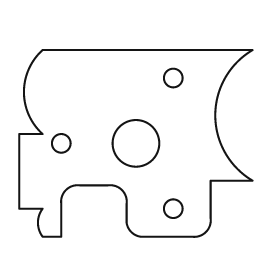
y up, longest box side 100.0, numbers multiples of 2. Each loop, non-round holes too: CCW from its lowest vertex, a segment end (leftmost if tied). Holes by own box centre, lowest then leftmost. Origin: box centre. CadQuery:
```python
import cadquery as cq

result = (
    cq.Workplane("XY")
    .moveTo(-40.0, -40.0)
    .lineTo(-32.0, -40.0)
    .lineTo(-32.0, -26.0)
    .threePointArc((-30.0, -20.0), (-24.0, -18.0))
    .lineTo(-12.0, -18.0)
    .threePointArc((-6.0, -20.0), (-4.0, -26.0))
    .lineTo(-4.0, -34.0)
    .threePointArc((-2.0, -38.0), (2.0, -40.0))
    .lineTo(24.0, -40.0)
    .threePointArc((30.0, -38.0), (32.0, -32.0))
    .lineTo(32.0, -16.0)
    .lineTo(50.0, -16.0)
    .threePointArc((34.0, 12.0), (50.0, 40.0))
    .lineTo(-40.0, 40.0)
    .threePointArc((-48.0, 22.0), (-40.0, 4.0))
    .lineTo(-50.0, 4.0)
    .lineTo(-50.0, -28.0)
    .lineTo(-40.0, -28.0)
    .threePointArc((-42.0, -34.0), (-40.0, -40.0))
    .close()
    .moveTo(16.0, -28.0)
    .circle(4.0)
    .moveTo(-32.0, 0.0)
    .circle(4.0)
    .moveTo(0.0, 0.0)
    .circle(10.0)
    .moveTo(16.0, 28.0)
    .circle(4.0)
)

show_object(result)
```